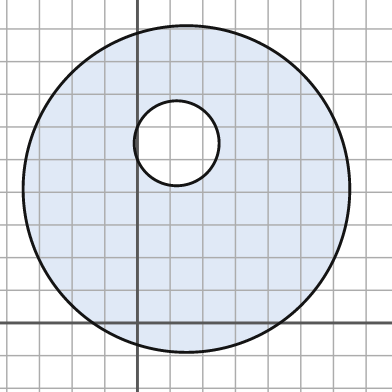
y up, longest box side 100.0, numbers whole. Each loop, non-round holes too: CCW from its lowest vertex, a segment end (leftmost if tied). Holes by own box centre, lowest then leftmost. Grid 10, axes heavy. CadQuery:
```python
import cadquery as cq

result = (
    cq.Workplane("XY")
    .moveTo(15.0, 41.0)
    .circle(50.0)
    .moveTo(12.0, 55.0)
    .circle(13.0)
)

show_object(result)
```